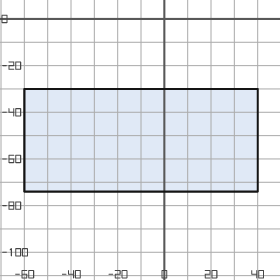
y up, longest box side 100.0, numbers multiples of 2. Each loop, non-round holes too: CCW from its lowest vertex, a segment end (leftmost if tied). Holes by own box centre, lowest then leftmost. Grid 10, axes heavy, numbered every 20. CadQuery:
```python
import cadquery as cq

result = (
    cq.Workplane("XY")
    .moveTo(-60.0, -74.0)
    .lineTo(40.0, -74.0)
    .lineTo(40.0, -30.0)
    .lineTo(-60.0, -30.0)
    .close()
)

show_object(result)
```